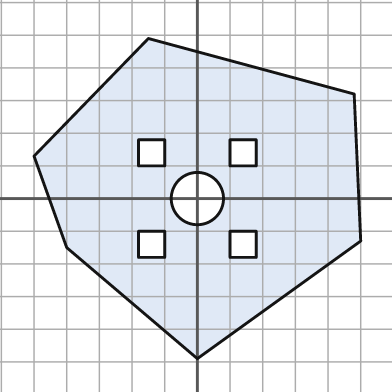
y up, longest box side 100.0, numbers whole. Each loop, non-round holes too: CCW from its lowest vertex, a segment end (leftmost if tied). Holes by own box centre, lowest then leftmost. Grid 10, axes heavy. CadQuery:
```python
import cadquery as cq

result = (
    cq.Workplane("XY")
    .moveTo(0.0, -49.0)
    .lineTo(50.0, -13.0)
    .lineTo(48.0, 32.0)
    .lineTo(-15.0, 49.0)
    .lineTo(-50.0, 13.0)
    .lineTo(-40.0, -15.0)
    .close()
    .moveTo(-18.0, -18.0)
    .lineTo(-10.0, -18.0)
    .lineTo(-10.0, -10.0)
    .lineTo(-18.0, -10.0)
    .close()
    .moveTo(10.0, -18.0)
    .lineTo(18.0, -18.0)
    .lineTo(18.0, -10.0)
    .lineTo(10.0, -10.0)
    .close()
    .moveTo(0.0, 0.0)
    .circle(8.0)
    .moveTo(-18.0, 10.0)
    .lineTo(-10.0, 10.0)
    .lineTo(-10.0, 18.0)
    .lineTo(-18.0, 18.0)
    .close()
    .moveTo(10.0, 10.0)
    .lineTo(18.0, 10.0)
    .lineTo(18.0, 18.0)
    .lineTo(10.0, 18.0)
    .close()
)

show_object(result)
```